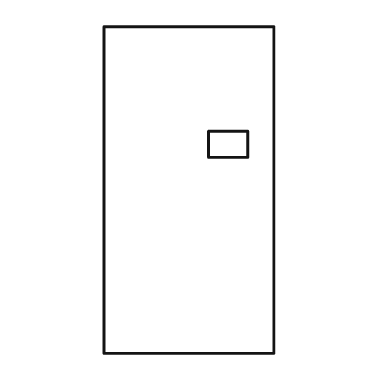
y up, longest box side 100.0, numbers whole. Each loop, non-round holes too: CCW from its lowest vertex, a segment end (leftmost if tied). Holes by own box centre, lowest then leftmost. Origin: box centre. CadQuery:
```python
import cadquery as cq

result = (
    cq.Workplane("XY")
    .moveTo(-26.0, -50.0)
    .lineTo(26.0, -50.0)
    .lineTo(26.0, 50.0)
    .lineTo(-26.0, 50.0)
    .close()
    .moveTo(6.0, 10.0)
    .lineTo(18.0, 10.0)
    .lineTo(18.0, 18.0)
    .lineTo(6.0, 18.0)
    .close()
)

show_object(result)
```